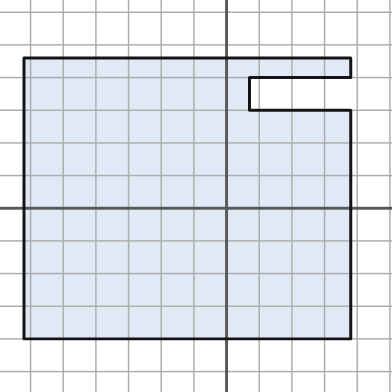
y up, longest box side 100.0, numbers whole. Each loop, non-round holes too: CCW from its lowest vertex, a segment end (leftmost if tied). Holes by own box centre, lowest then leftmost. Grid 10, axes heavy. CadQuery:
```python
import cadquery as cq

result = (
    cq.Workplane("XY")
    .moveTo(-62.0, -40.0)
    .lineTo(38.0, -40.0)
    .lineTo(38.0, 30.0)
    .lineTo(7.0, 30.0)
    .lineTo(7.0, 40.0)
    .lineTo(38.0, 40.0)
    .lineTo(38.0, 46.0)
    .lineTo(-62.0, 46.0)
    .close()
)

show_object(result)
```